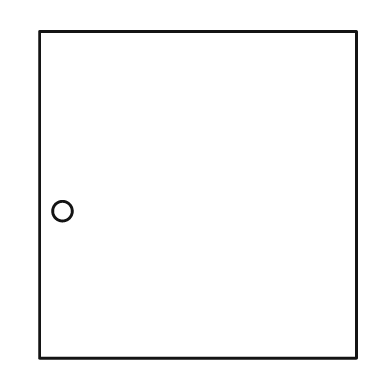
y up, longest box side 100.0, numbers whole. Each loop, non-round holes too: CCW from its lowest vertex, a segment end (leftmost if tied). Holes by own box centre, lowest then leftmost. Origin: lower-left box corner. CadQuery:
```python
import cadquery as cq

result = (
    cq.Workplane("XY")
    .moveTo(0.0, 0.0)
    .lineTo(97.0, 0.0)
    .lineTo(97.0, 100.0)
    .lineTo(0.0, 100.0)
    .close()
    .moveTo(7.0, 45.0)
    .circle(3.0)
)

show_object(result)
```